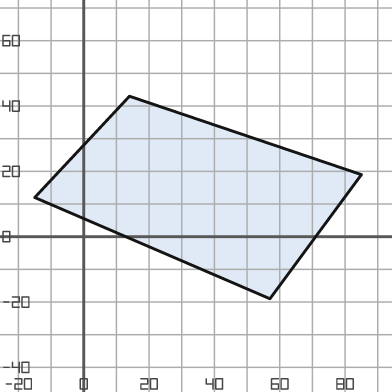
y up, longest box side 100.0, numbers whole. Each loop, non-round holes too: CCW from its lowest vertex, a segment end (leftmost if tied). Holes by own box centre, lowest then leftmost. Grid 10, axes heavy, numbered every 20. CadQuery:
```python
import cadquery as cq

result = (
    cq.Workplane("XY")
    .moveTo(57.0, -19.0)
    .lineTo(85.0, 19.0)
    .lineTo(14.0, 43.0)
    .lineTo(-15.0, 12.0)
    .close()
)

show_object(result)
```